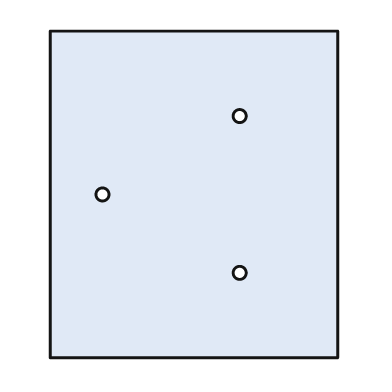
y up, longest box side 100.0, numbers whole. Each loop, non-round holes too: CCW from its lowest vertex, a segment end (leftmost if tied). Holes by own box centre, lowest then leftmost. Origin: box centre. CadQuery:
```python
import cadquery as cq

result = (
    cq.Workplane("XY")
    .moveTo(-44.0, -50.0)
    .lineTo(44.0, -50.0)
    .lineTo(44.0, 50.0)
    .lineTo(-44.0, 50.0)
    .close()
    .moveTo(14.0, -24.0)
    .circle(2.0)
    .moveTo(-28.0, 0.0)
    .circle(2.0)
    .moveTo(14.0, 24.0)
    .circle(2.0)
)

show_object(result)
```